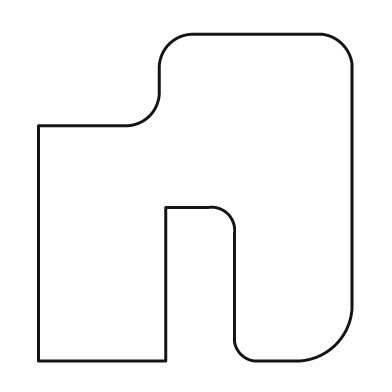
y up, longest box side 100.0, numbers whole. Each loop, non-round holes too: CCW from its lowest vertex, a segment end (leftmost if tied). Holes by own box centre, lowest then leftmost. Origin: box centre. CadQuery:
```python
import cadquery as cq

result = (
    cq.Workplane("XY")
    .moveTo(-48.0, -50.0)
    .lineTo(-9.0, -50.0)
    .lineTo(-9.0, -3.0)
    .lineTo(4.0, -3.0)
    .threePointArc((10.0, -5.0), (12.0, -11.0))
    .lineTo(12.0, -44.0)
    .threePointArc((14.0, -48.0), (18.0, -50.0))
    .lineTo(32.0, -50.0)
    .threePointArc((43.0, -45.0), (48.0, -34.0))
    .lineTo(48.0, 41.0)
    .threePointArc((45.0, 47.0), (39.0, 50.0))
    .lineTo(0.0, 50.0)
    .threePointArc((-8.0, 47.0), (-11.0, 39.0))
    .lineTo(-11.0, 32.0)
    .threePointArc((-14.0, 25.0), (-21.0, 22.0))
    .lineTo(-48.0, 22.0)
    .close()
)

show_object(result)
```